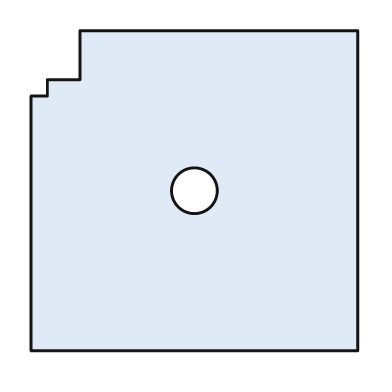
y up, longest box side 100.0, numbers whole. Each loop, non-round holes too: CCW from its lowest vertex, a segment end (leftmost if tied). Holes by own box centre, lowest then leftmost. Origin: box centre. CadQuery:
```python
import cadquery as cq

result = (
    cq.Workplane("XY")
    .moveTo(-50.0, -49.0)
    .lineTo(50.0, -49.0)
    .lineTo(50.0, 49.0)
    .lineTo(-35.0, 49.0)
    .lineTo(-35.0, 34.0)
    .lineTo(-45.0, 34.0)
    .lineTo(-45.0, 29.0)
    .lineTo(-50.0, 29.0)
    .close()
    .moveTo(0.0, 0.0)
    .circle(7.0)
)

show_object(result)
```